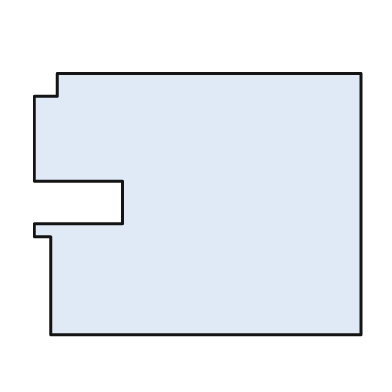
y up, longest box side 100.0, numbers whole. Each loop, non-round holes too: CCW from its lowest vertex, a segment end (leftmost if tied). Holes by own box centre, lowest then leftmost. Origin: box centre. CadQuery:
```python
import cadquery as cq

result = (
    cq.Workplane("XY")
    .moveTo(-45.0, -40.0)
    .lineTo(50.0, -40.0)
    .lineTo(50.0, 40.0)
    .lineTo(-43.0, 40.0)
    .lineTo(-43.0, 33.0)
    .lineTo(-50.0, 33.0)
    .lineTo(-50.0, 7.0)
    .lineTo(-23.0, 7.0)
    .lineTo(-23.0, -6.0)
    .lineTo(-50.0, -6.0)
    .lineTo(-50.0, -10.0)
    .lineTo(-45.0, -10.0)
    .close()
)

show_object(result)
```